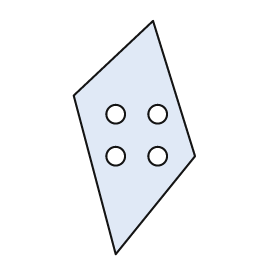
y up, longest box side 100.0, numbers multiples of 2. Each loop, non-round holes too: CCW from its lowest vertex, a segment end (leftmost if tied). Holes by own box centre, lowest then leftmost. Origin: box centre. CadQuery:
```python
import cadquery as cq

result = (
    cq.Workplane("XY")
    .moveTo(-8.0, -50.0)
    .lineTo(26.0, -8.0)
    .lineTo(8.0, 50.0)
    .lineTo(-26.0, 18.0)
    .close()
    .moveTo(-8.0, -8.0)
    .circle(4.0)
    .moveTo(10.0, -8.0)
    .circle(4.0)
    .moveTo(-8.0, 10.0)
    .circle(4.0)
    .moveTo(10.0, 10.0)
    .circle(4.0)
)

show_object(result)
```